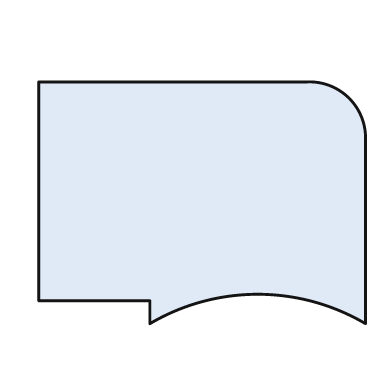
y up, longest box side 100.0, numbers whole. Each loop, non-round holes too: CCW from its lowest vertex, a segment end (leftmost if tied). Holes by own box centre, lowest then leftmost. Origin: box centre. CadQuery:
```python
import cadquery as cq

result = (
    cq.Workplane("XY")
    .moveTo(-16.0, -37.0)
    .threePointArc((17.0, -28.0), (50.0, -37.0))
    .lineTo(50.0, 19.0)
    .threePointArc((45.0, 32.0), (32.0, 37.0))
    .lineTo(-50.0, 37.0)
    .lineTo(-50.0, -30.0)
    .lineTo(-16.0, -30.0)
    .close()
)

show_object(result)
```